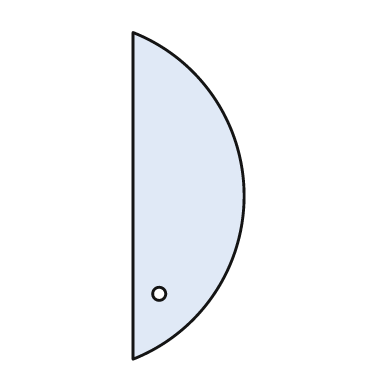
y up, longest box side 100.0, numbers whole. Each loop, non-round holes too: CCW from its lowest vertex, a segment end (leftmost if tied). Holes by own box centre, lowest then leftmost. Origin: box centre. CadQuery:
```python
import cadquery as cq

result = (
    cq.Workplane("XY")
    .moveTo(-17.0, -50.0)
    .threePointArc((17.0, 0.0), (-17.0, 50.0))
    .close()
    .moveTo(-9.0, -30.0)
    .circle(2.0)
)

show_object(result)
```